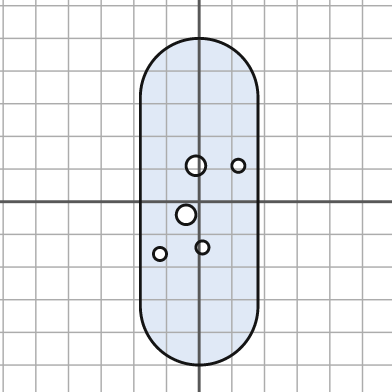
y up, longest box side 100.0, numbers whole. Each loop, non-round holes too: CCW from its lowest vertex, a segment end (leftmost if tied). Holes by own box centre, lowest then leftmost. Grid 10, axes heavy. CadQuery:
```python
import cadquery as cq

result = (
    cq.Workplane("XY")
    .moveTo(-18.0, -32.0)
    .threePointArc((0.0, -50.0), (18.0, -32.0))
    .lineTo(18.0, 32.0)
    .threePointArc((0.0, 50.0), (-18.0, 32.0))
    .close()
    .moveTo(-12.0, -16.0)
    .circle(2.0)
    .moveTo(1.0, -14.0)
    .circle(2.0)
    .moveTo(-4.0, -4.0)
    .circle(3.0)
    .moveTo(-1.0, 11.0)
    .circle(3.0)
    .moveTo(12.0, 11.0)
    .circle(2.0)
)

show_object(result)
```